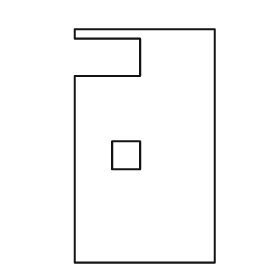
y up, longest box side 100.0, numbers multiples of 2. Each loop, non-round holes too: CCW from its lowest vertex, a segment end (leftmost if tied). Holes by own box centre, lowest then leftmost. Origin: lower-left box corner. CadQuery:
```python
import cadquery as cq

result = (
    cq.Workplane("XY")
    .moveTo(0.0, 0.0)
    .lineTo(60.0, 0.0)
    .lineTo(60.0, 100.0)
    .lineTo(0.0, 100.0)
    .lineTo(0.0, 96.0)
    .lineTo(28.0, 96.0)
    .lineTo(28.0, 80.0)
    .lineTo(0.0, 80.0)
    .close()
    .moveTo(16.0, 40.0)
    .lineTo(28.0, 40.0)
    .lineTo(28.0, 52.0)
    .lineTo(16.0, 52.0)
    .close()
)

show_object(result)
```